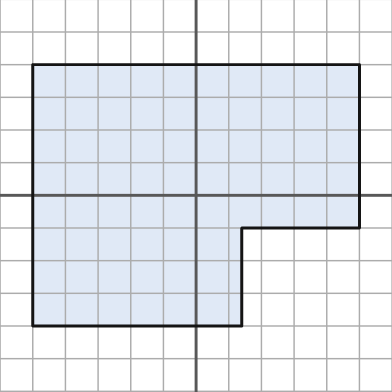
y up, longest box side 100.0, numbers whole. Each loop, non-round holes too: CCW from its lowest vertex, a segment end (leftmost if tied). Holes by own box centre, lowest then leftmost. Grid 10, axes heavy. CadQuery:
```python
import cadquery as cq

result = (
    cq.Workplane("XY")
    .moveTo(-50.0, -40.0)
    .lineTo(14.0, -40.0)
    .lineTo(14.0, -10.0)
    .lineTo(50.0, -10.0)
    .lineTo(50.0, 40.0)
    .lineTo(-50.0, 40.0)
    .close()
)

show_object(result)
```